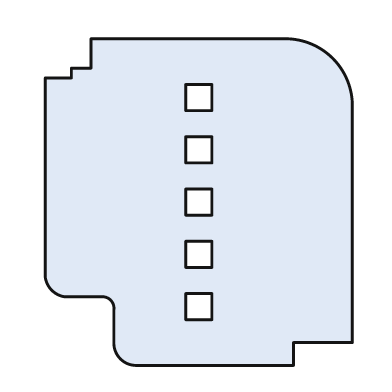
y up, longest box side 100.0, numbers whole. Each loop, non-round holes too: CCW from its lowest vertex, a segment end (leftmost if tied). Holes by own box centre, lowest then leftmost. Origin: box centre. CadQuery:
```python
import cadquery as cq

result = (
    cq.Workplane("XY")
    .moveTo(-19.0, -50.0)
    .lineTo(29.0, -50.0)
    .lineTo(29.0, -43.0)
    .lineTo(47.0, -43.0)
    .lineTo(47.0, 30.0)
    .threePointArc((41.0, 44.0), (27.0, 50.0))
    .lineTo(-33.0, 50.0)
    .lineTo(-33.0, 41.0)
    .lineTo(-39.0, 41.0)
    .lineTo(-39.0, 38.0)
    .lineTo(-47.0, 38.0)
    .lineTo(-47.0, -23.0)
    .threePointArc((-45.0, -27.0), (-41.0, -29.0))
    .lineTo(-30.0, -29.0)
    .threePointArc((-27.0, -30.0), (-26.0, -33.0))
    .lineTo(-26.0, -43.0)
    .threePointArc((-24.0, -48.0), (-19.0, -50.0))
    .close()
    .moveTo(-4.0, -36.0)
    .lineTo(4.0, -36.0)
    .lineTo(4.0, -28.0)
    .lineTo(-4.0, -28.0)
    .close()
    .moveTo(-4.0, -20.0)
    .lineTo(4.0, -20.0)
    .lineTo(4.0, -12.0)
    .lineTo(-4.0, -12.0)
    .close()
    .moveTo(-4.0, -4.0)
    .lineTo(4.0, -4.0)
    .lineTo(4.0, 4.0)
    .lineTo(-4.0, 4.0)
    .close()
    .moveTo(-4.0, 12.0)
    .lineTo(4.0, 12.0)
    .lineTo(4.0, 20.0)
    .lineTo(-4.0, 20.0)
    .close()
    .moveTo(-4.0, 28.0)
    .lineTo(4.0, 28.0)
    .lineTo(4.0, 36.0)
    .lineTo(-4.0, 36.0)
    .close()
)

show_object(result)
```